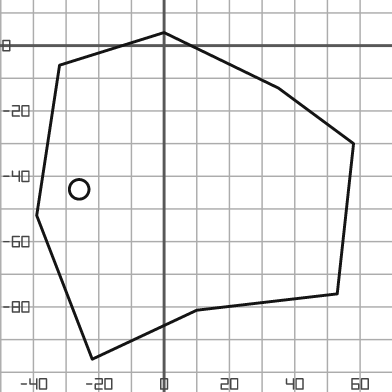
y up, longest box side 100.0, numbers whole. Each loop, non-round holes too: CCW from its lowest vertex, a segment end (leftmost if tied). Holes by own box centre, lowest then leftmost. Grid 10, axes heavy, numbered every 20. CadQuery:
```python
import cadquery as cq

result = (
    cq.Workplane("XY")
    .moveTo(-22.0, -96.0)
    .lineTo(10.0, -81.0)
    .lineTo(53.0, -76.0)
    .lineTo(58.0, -30.0)
    .lineTo(35.0, -13.0)
    .lineTo(0.0, 4.0)
    .lineTo(-32.0, -6.0)
    .lineTo(-39.0, -52.0)
    .close()
    .moveTo(-26.0, -44.0)
    .circle(3.0)
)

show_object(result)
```